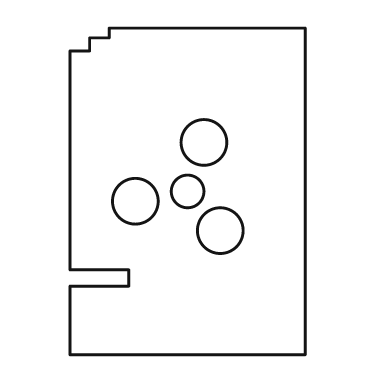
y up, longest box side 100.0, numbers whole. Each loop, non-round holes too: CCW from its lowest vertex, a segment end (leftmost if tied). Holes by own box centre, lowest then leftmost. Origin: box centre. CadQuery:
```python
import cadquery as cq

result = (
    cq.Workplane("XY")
    .moveTo(-36.0, -50.0)
    .lineTo(36.0, -50.0)
    .lineTo(36.0, 50.0)
    .lineTo(-24.0, 50.0)
    .lineTo(-24.0, 47.0)
    .lineTo(-30.0, 47.0)
    .lineTo(-30.0, 43.0)
    .lineTo(-36.0, 43.0)
    .lineTo(-36.0, -24.0)
    .lineTo(-18.0, -24.0)
    .lineTo(-18.0, -29.0)
    .lineTo(-36.0, -29.0)
    .close()
    .moveTo(10.0, -12.0)
    .circle(7.0)
    .moveTo(-16.0, -3.0)
    .circle(7.0)
    .moveTo(0.0, 0.0)
    .circle(5.0)
    .moveTo(5.0, 15.0)
    .circle(7.0)
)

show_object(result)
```